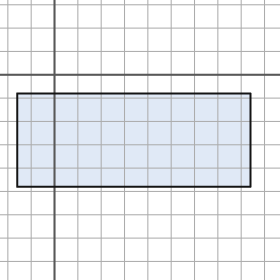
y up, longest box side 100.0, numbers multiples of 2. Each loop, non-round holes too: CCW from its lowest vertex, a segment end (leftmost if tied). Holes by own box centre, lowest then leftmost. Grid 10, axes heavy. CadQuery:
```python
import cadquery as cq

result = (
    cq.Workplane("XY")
    .moveTo(-16.0, -48.0)
    .lineTo(84.0, -48.0)
    .lineTo(84.0, -8.0)
    .lineTo(-16.0, -8.0)
    .close()
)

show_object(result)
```